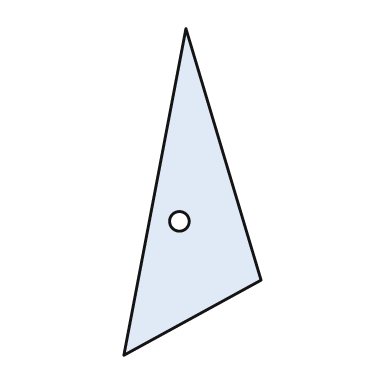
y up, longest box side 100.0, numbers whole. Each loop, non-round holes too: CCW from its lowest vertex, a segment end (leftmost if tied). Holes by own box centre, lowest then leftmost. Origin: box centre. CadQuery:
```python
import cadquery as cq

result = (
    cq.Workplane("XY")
    .moveTo(-21.0, -50.0)
    .lineTo(21.0, -27.0)
    .lineTo(-2.0, 50.0)
    .close()
    .moveTo(-4.0, -9.0)
    .circle(3.0)
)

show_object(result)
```